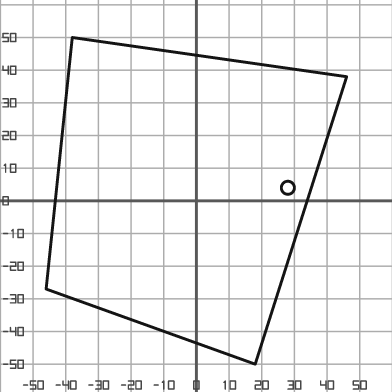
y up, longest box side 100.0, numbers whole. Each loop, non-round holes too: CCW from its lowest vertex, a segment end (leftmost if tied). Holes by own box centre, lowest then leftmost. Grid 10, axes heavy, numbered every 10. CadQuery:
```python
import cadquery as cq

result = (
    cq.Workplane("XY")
    .moveTo(18.0, -50.0)
    .lineTo(46.0, 38.0)
    .lineTo(-38.0, 50.0)
    .lineTo(-46.0, -27.0)
    .close()
    .moveTo(28.0, 4.0)
    .circle(2.0)
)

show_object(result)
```